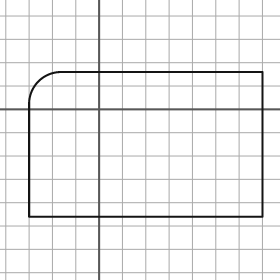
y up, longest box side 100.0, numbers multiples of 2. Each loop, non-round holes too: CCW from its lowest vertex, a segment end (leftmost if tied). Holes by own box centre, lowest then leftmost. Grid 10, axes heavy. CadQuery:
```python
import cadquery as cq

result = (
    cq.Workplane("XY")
    .moveTo(-30.0, -46.0)
    .lineTo(70.0, -46.0)
    .lineTo(70.0, 16.0)
    .lineTo(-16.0, 16.0)
    .threePointArc((-26.0, 12.0), (-30.0, 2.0))
    .close()
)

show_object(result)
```